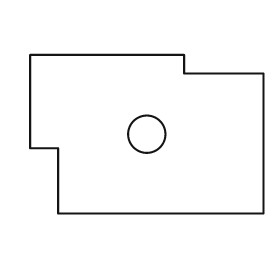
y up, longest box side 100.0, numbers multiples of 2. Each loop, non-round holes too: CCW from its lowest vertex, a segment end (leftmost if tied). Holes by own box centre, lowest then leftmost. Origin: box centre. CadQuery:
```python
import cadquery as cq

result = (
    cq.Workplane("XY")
    .moveTo(-38.0, -34.0)
    .lineTo(50.0, -34.0)
    .lineTo(50.0, 26.0)
    .lineTo(16.0, 26.0)
    .lineTo(16.0, 34.0)
    .lineTo(-50.0, 34.0)
    .lineTo(-50.0, -6.0)
    .lineTo(-38.0, -6.0)
    .close()
    .moveTo(0.0, 0.0)
    .circle(8.0)
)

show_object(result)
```